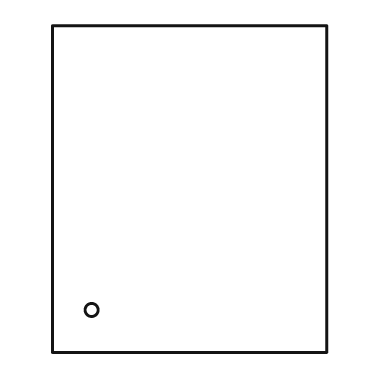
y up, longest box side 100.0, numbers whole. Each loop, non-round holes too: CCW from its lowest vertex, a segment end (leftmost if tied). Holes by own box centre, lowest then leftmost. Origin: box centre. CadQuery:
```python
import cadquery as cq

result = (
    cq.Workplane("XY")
    .moveTo(-42.0, -50.0)
    .lineTo(42.0, -50.0)
    .lineTo(42.0, 50.0)
    .lineTo(-42.0, 50.0)
    .close()
    .moveTo(-30.0, -37.0)
    .circle(2.0)
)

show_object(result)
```